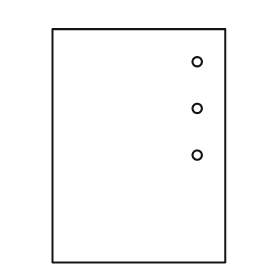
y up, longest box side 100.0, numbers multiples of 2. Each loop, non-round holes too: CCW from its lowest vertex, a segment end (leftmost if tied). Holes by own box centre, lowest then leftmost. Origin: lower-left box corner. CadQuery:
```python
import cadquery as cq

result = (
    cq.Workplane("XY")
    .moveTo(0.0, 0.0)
    .lineTo(74.0, 0.0)
    .lineTo(74.0, 100.0)
    .lineTo(0.0, 100.0)
    .close()
    .moveTo(62.0, 46.0)
    .circle(2.0)
    .moveTo(62.0, 66.0)
    .circle(2.0)
    .moveTo(62.0, 86.0)
    .circle(2.0)
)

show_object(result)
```